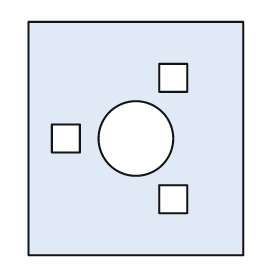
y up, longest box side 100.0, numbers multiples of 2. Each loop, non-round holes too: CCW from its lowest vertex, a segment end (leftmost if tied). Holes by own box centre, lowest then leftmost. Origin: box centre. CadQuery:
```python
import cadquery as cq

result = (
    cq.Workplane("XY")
    .moveTo(-46.0, -50.0)
    .lineTo(46.0, -50.0)
    .lineTo(46.0, 50.0)
    .lineTo(-46.0, 50.0)
    .close()
    .moveTo(10.0, -32.0)
    .lineTo(22.0, -32.0)
    .lineTo(22.0, -20.0)
    .lineTo(10.0, -20.0)
    .close()
    .moveTo(-36.0, -6.0)
    .lineTo(-24.0, -6.0)
    .lineTo(-24.0, 6.0)
    .lineTo(-36.0, 6.0)
    .close()
    .moveTo(0.0, 0.0)
    .circle(16.0)
    .moveTo(10.0, 20.0)
    .lineTo(22.0, 20.0)
    .lineTo(22.0, 32.0)
    .lineTo(10.0, 32.0)
    .close()
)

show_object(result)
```